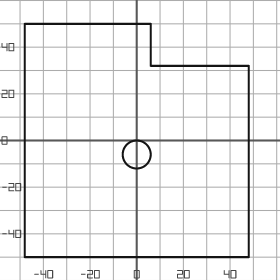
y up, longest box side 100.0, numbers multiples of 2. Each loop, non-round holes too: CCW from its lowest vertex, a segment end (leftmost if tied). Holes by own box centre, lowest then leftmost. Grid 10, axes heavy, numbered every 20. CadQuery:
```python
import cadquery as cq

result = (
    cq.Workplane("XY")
    .moveTo(-48.0, -50.0)
    .lineTo(48.0, -50.0)
    .lineTo(48.0, 32.0)
    .lineTo(6.0, 32.0)
    .lineTo(6.0, 50.0)
    .lineTo(-48.0, 50.0)
    .close()
    .moveTo(0.0, -6.0)
    .circle(6.0)
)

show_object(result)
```